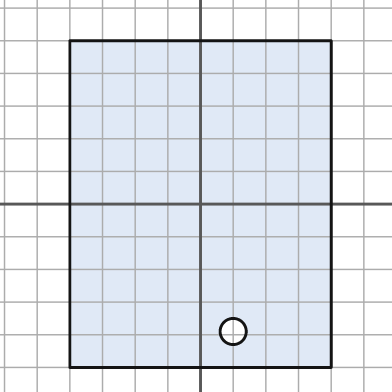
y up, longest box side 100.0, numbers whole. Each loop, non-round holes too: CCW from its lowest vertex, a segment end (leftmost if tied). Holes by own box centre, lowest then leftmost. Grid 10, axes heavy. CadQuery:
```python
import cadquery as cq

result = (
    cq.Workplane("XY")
    .moveTo(-40.0, -50.0)
    .lineTo(40.0, -50.0)
    .lineTo(40.0, 50.0)
    .lineTo(-40.0, 50.0)
    .close()
    .moveTo(10.0, -39.0)
    .circle(4.0)
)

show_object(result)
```